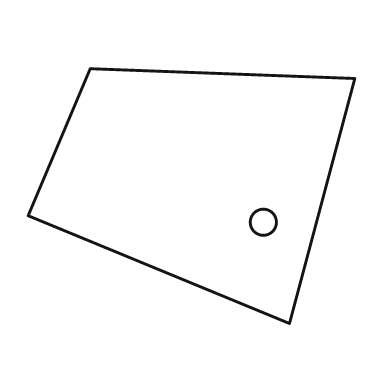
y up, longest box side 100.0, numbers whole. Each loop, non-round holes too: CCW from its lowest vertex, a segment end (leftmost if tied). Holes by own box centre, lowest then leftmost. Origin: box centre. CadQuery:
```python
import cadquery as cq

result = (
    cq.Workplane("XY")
    .moveTo(30.0, -39.0)
    .lineTo(50.0, 36.0)
    .lineTo(-31.0, 39.0)
    .lineTo(-50.0, -6.0)
    .close()
    .moveTo(22.0, -8.0)
    .circle(4.0)
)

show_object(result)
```